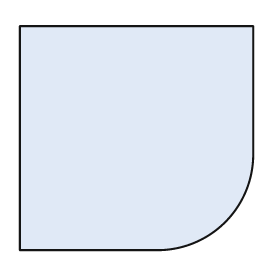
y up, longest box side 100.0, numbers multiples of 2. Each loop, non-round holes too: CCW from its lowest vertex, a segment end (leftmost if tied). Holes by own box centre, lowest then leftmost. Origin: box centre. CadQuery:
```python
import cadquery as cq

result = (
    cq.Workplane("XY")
    .moveTo(-50.0, -48.0)
    .lineTo(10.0, -48.0)
    .threePointArc((38.0, -36.0), (50.0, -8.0))
    .lineTo(50.0, 48.0)
    .lineTo(-50.0, 48.0)
    .close()
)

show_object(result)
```